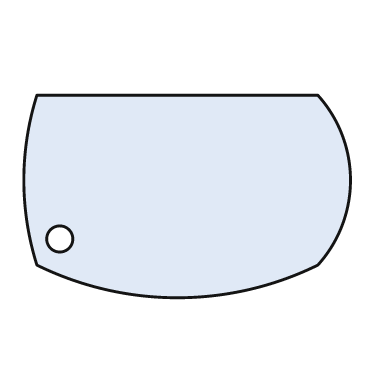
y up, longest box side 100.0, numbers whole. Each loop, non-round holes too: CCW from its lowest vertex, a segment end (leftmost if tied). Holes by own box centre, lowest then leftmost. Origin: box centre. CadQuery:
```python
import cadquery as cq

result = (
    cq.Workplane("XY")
    .moveTo(-46.0, -21.0)
    .threePointArc((-3.0, -31.0), (40.0, -21.0))
    .threePointArc((50.0, 5.0), (40.0, 31.0))
    .lineTo(-46.0, 31.0)
    .threePointArc((-50.0, 5.0), (-46.0, -21.0))
    .close()
    .moveTo(-39.0, -13.0)
    .circle(4.0)
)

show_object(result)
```